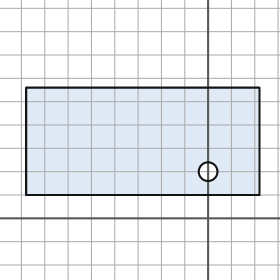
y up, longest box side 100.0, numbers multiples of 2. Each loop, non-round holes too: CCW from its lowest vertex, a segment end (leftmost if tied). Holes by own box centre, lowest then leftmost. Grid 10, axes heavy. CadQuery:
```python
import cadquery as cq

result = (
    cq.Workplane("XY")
    .moveTo(-78.0, 10.0)
    .lineTo(22.0, 10.0)
    .lineTo(22.0, 56.0)
    .lineTo(-78.0, 56.0)
    .close()
    .moveTo(0.0, 20.0)
    .circle(4.0)
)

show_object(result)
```